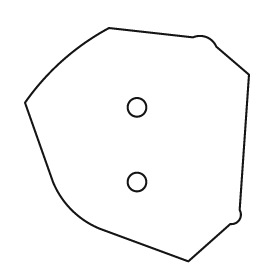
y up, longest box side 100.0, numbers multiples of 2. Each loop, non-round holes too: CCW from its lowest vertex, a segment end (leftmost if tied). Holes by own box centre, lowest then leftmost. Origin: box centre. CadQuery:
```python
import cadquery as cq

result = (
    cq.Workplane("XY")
    .moveTo(22.0, -50.0)
    .lineTo(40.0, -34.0)
    .threePointArc((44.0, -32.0), (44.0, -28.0))
    .lineTo(48.0, 30.0)
    .lineTo(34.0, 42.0)
    .threePointArc((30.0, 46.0), (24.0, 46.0))
    .lineTo(-12.0, 50.0)
    .threePointArc((-32.0, 36.0), (-48.0, 18.0))
    .lineTo(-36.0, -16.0)
    .threePointArc((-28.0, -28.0), (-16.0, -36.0))
    .close()
    .moveTo(0.0, -16.0)
    .circle(4.0)
    .moveTo(0.0, 16.0)
    .circle(4.0)
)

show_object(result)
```